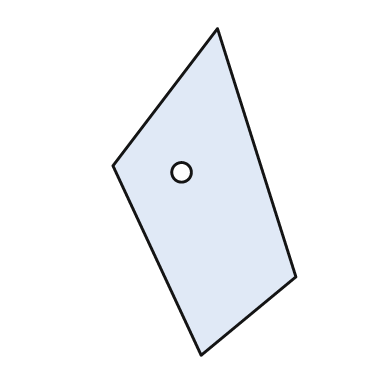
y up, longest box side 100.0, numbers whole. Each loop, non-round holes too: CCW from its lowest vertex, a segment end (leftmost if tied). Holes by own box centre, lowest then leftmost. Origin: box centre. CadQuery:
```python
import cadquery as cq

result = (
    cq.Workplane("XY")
    .moveTo(-1.0, -50.0)
    .lineTo(28.0, -26.0)
    .lineTo(4.0, 50.0)
    .lineTo(-28.0, 8.0)
    .close()
    .moveTo(-7.0, 6.0)
    .circle(3.0)
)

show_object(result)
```